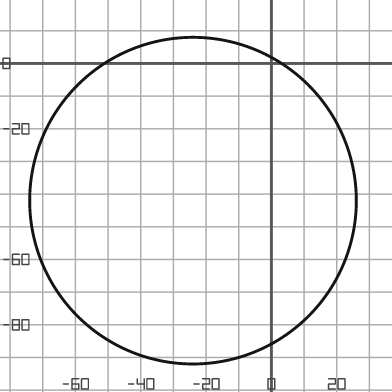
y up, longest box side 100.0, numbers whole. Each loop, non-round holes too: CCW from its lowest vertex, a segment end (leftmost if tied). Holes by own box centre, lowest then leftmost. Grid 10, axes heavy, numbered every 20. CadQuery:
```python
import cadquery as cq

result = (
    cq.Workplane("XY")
    .moveTo(-24.0, -42.0)
    .circle(50.0)
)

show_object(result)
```